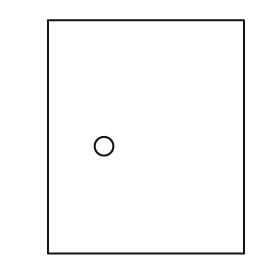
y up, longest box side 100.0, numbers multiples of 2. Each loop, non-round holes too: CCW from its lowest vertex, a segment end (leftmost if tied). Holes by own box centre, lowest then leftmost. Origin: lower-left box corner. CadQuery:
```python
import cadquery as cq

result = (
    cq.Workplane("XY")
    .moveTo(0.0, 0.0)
    .lineTo(84.0, 0.0)
    .lineTo(84.0, 100.0)
    .lineTo(0.0, 100.0)
    .close()
    .moveTo(24.0, 46.0)
    .circle(4.0)
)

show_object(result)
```